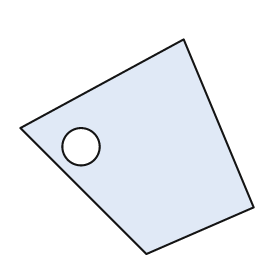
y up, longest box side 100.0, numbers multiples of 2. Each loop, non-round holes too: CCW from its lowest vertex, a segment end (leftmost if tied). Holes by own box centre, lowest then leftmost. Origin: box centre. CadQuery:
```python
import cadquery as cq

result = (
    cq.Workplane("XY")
    .moveTo(4.0, -46.0)
    .lineTo(50.0, -26.0)
    .lineTo(20.0, 46.0)
    .lineTo(-50.0, 8.0)
    .close()
    .moveTo(-24.0, 0.0)
    .circle(8.0)
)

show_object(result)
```